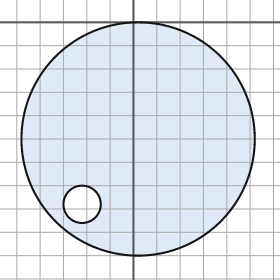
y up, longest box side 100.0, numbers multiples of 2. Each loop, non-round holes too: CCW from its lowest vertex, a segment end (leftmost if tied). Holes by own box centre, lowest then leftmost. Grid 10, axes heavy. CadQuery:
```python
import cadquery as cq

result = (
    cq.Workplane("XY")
    .moveTo(2.0, -50.0)
    .circle(50.0)
    .moveTo(-22.0, -78.0)
    .circle(8.0)
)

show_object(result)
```